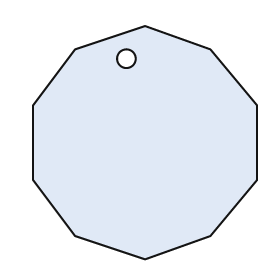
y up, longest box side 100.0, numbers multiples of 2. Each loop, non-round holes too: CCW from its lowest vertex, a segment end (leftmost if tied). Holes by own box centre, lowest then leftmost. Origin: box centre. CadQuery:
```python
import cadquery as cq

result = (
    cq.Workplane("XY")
    .moveTo(0.0, -50.0)
    .lineTo(28.0, -40.0)
    .lineTo(48.0, -16.0)
    .lineTo(48.0, 16.0)
    .lineTo(28.0, 40.0)
    .lineTo(0.0, 50.0)
    .lineTo(-30.0, 40.0)
    .lineTo(-48.0, 16.0)
    .lineTo(-48.0, -16.0)
    .lineTo(-30.0, -40.0)
    .close()
    .moveTo(-8.0, 36.0)
    .circle(4.0)
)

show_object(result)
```